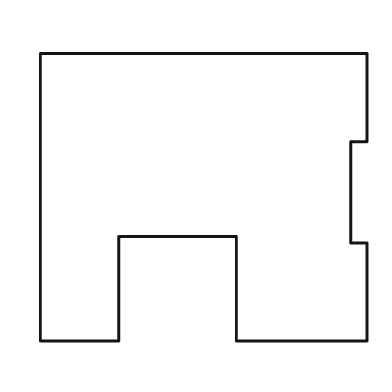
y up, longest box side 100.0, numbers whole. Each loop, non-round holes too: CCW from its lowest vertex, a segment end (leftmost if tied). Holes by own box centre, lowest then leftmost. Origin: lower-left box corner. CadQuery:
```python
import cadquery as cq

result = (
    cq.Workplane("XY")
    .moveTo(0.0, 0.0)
    .lineTo(24.0, 0.0)
    .lineTo(24.0, 32.0)
    .lineTo(60.0, 32.0)
    .lineTo(60.0, 0.0)
    .lineTo(100.0, 0.0)
    .lineTo(100.0, 30.0)
    .lineTo(95.0, 30.0)
    .lineTo(95.0, 61.0)
    .lineTo(100.0, 61.0)
    .lineTo(100.0, 88.0)
    .lineTo(0.0, 88.0)
    .close()
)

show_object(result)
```